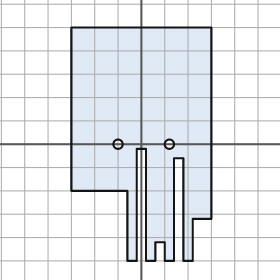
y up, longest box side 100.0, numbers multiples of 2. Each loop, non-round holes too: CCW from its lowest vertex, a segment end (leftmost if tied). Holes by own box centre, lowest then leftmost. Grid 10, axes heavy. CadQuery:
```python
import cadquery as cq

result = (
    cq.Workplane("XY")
    .moveTo(-6.0, -50.0)
    .lineTo(-2.0, -50.0)
    .lineTo(-2.0, -2.0)
    .lineTo(2.0, -2.0)
    .lineTo(2.0, -50.0)
    .lineTo(6.0, -50.0)
    .lineTo(6.0, -42.0)
    .lineTo(10.0, -42.0)
    .lineTo(10.0, -50.0)
    .lineTo(14.0, -50.0)
    .lineTo(14.0, -6.0)
    .lineTo(18.0, -6.0)
    .lineTo(18.0, -50.0)
    .lineTo(22.0, -50.0)
    .lineTo(22.0, -32.0)
    .lineTo(30.0, -32.0)
    .lineTo(30.0, 50.0)
    .lineTo(-30.0, 50.0)
    .lineTo(-30.0, -20.0)
    .lineTo(-6.0, -20.0)
    .close()
    .moveTo(-10.0, 0.0)
    .circle(2.0)
    .moveTo(12.0, 0.0)
    .circle(2.0)
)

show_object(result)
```